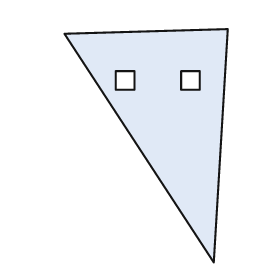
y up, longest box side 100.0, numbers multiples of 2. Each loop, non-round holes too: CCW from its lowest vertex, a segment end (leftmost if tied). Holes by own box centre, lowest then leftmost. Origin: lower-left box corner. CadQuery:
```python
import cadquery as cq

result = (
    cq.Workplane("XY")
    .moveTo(64.0, 0.0)
    .lineTo(70.0, 100.0)
    .lineTo(0.0, 98.0)
    .close()
    .moveTo(22.0, 74.0)
    .lineTo(30.0, 74.0)
    .lineTo(30.0, 82.0)
    .lineTo(22.0, 82.0)
    .close()
    .moveTo(50.0, 74.0)
    .lineTo(58.0, 74.0)
    .lineTo(58.0, 82.0)
    .lineTo(50.0, 82.0)
    .close()
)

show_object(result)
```